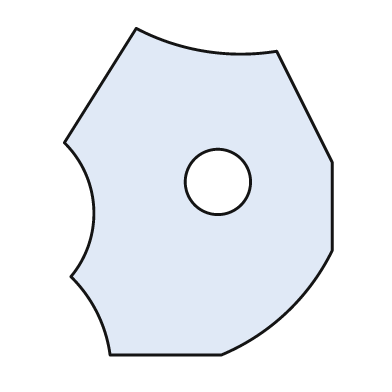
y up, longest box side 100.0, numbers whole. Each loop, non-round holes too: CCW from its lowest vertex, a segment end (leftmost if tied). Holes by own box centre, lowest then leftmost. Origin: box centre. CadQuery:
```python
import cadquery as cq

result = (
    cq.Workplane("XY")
    .moveTo(-27.0, -50.0)
    .lineTo(7.0, -50.0)
    .threePointArc((27.0, -37.0), (41.0, -18.0))
    .lineTo(41.0, 9.0)
    .lineTo(24.0, 43.0)
    .threePointArc((2.0, 43.0), (-19.0, 50.0))
    .lineTo(-41.0, 15.0)
    .threePointArc((-32.0, -5.0), (-39.0, -26.0))
    .threePointArc((-31.0, -37.0), (-27.0, -50.0))
    .close()
    .moveTo(6.0, 3.0)
    .circle(10.0)
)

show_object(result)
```